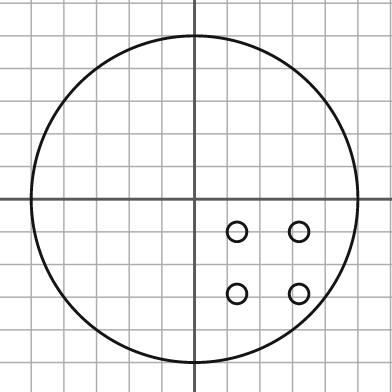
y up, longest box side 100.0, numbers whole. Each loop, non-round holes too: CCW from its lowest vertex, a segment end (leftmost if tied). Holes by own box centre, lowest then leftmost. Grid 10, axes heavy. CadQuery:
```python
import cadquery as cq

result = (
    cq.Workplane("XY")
    .moveTo(0.0, 0.0)
    .circle(50.0)
    .moveTo(13.0, -29.0)
    .circle(3.0)
    .moveTo(32.0, -29.0)
    .circle(3.0)
    .moveTo(13.0, -10.0)
    .circle(3.0)
    .moveTo(32.0, -10.0)
    .circle(3.0)
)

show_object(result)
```